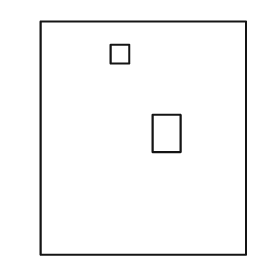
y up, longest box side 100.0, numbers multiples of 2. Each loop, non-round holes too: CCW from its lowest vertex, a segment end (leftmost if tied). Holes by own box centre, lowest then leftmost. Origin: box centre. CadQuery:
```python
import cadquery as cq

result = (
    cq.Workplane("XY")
    .moveTo(-44.0, -50.0)
    .lineTo(44.0, -50.0)
    .lineTo(44.0, 50.0)
    .lineTo(-44.0, 50.0)
    .close()
    .moveTo(4.0, -6.0)
    .lineTo(16.0, -6.0)
    .lineTo(16.0, 10.0)
    .lineTo(4.0, 10.0)
    .close()
    .moveTo(-14.0, 32.0)
    .lineTo(-6.0, 32.0)
    .lineTo(-6.0, 40.0)
    .lineTo(-14.0, 40.0)
    .close()
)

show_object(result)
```